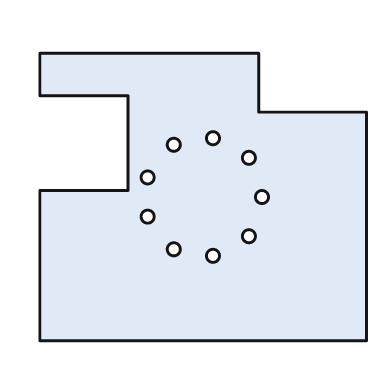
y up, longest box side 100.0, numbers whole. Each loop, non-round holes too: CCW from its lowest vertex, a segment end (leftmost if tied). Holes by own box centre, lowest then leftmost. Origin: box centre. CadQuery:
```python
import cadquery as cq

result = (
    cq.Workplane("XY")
    .moveTo(-50.0, -44.0)
    .lineTo(50.0, -44.0)
    .lineTo(50.0, 26.0)
    .lineTo(17.0, 26.0)
    .lineTo(17.0, 44.0)
    .lineTo(-50.0, 44.0)
    .lineTo(-50.0, 31.0)
    .lineTo(-23.0, 31.0)
    .lineTo(-23.0, 2.0)
    .lineTo(-50.0, 2.0)
    .close()
    .moveTo(3.0, -18.0)
    .circle(2.0)
    .moveTo(-9.0, -16.0)
    .circle(2.0)
    .moveTo(14.0, -12.0)
    .circle(2.0)
    .moveTo(-17.0, -6.0)
    .circle(2.0)
    .moveTo(18.0, 0.0)
    .circle(2.0)
    .moveTo(-17.0, 6.0)
    .circle(2.0)
    .moveTo(14.0, 12.0)
    .circle(2.0)
    .moveTo(-9.0, 16.0)
    .circle(2.0)
    .moveTo(3.0, 18.0)
    .circle(2.0)
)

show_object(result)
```